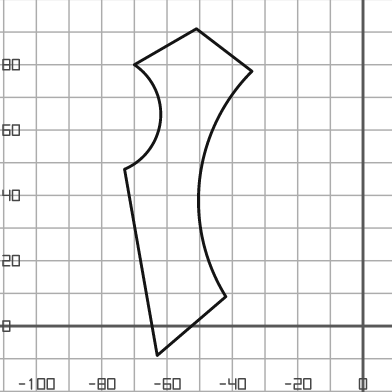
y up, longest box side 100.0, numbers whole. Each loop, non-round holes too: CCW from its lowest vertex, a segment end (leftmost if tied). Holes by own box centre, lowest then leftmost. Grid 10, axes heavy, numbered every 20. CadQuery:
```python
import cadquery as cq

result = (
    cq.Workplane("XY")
    .moveTo(-63.0, -9.0)
    .lineTo(-42.0, 9.0)
    .threePointArc((-50.0, 45.0), (-34.0, 78.0))
    .lineTo(-51.0, 91.0)
    .lineTo(-70.0, 80.0)
    .threePointArc((-62.0, 63.0), (-73.0, 48.0))
    .close()
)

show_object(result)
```